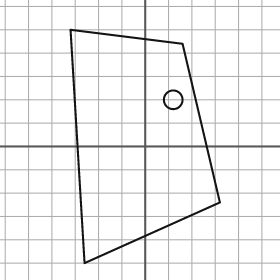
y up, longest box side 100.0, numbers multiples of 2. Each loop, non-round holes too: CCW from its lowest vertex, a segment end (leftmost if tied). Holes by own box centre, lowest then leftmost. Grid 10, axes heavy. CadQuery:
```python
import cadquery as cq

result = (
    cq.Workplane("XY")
    .moveTo(-26.0, -50.0)
    .lineTo(32.0, -24.0)
    .lineTo(16.0, 44.0)
    .lineTo(-32.0, 50.0)
    .close()
    .moveTo(12.0, 20.0)
    .circle(4.0)
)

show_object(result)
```